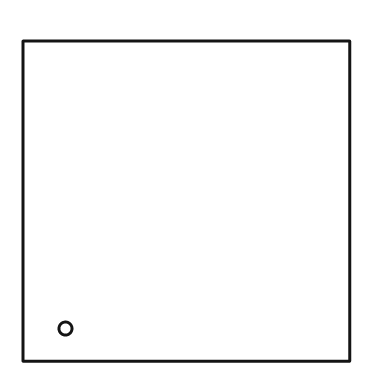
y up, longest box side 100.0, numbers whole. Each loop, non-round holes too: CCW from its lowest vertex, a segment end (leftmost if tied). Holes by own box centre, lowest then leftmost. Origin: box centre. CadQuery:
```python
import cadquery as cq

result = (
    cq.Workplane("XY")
    .moveTo(-50.0, -49.0)
    .lineTo(50.0, -49.0)
    .lineTo(50.0, 49.0)
    .lineTo(-50.0, 49.0)
    .close()
    .moveTo(-37.0, -39.0)
    .circle(2.0)
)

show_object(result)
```